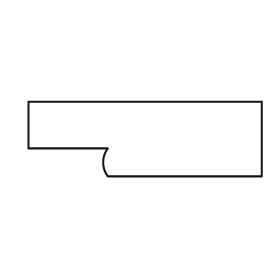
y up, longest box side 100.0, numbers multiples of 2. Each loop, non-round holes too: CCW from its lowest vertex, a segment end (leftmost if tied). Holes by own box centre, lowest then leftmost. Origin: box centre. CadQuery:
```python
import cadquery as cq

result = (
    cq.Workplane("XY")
    .moveTo(-16.0, -16.0)
    .lineTo(50.0, -16.0)
    .lineTo(50.0, 16.0)
    .lineTo(-50.0, 16.0)
    .lineTo(-50.0, -4.0)
    .lineTo(-16.0, -4.0)
    .threePointArc((-18.0, -10.0), (-16.0, -16.0))
    .close()
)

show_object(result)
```